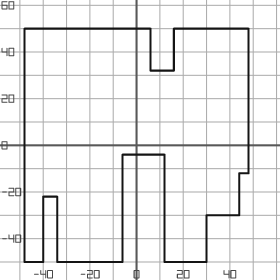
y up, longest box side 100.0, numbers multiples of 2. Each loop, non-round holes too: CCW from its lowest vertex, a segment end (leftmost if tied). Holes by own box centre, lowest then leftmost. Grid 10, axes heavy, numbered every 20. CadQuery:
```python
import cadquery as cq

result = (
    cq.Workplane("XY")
    .moveTo(-48.0, -50.0)
    .lineTo(-40.0, -50.0)
    .lineTo(-40.0, -22.0)
    .lineTo(-34.0, -22.0)
    .lineTo(-34.0, -50.0)
    .lineTo(-6.0, -50.0)
    .lineTo(-6.0, -4.0)
    .lineTo(12.0, -4.0)
    .lineTo(12.0, -50.0)
    .lineTo(30.0, -50.0)
    .lineTo(30.0, -30.0)
    .lineTo(44.0, -30.0)
    .lineTo(44.0, -12.0)
    .lineTo(48.0, -12.0)
    .lineTo(48.0, 50.0)
    .lineTo(16.0, 50.0)
    .lineTo(16.0, 32.0)
    .lineTo(6.0, 32.0)
    .lineTo(6.0, 50.0)
    .lineTo(-48.0, 50.0)
    .close()
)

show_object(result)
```